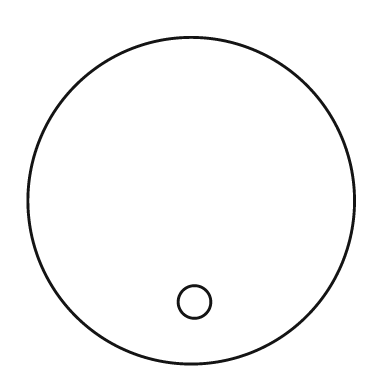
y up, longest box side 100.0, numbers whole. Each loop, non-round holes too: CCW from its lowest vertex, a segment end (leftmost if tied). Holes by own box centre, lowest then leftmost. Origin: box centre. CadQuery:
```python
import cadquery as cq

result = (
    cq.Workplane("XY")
    .moveTo(0.0, 0.0)
    .circle(50.0)
    .moveTo(1.0, -31.0)
    .circle(5.0)
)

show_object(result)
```